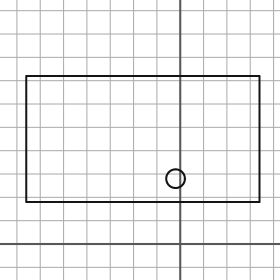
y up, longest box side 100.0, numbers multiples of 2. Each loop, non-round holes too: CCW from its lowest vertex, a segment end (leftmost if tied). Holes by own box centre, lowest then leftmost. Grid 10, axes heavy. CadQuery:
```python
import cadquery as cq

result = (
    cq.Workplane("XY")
    .moveTo(-66.0, 18.0)
    .lineTo(34.0, 18.0)
    .lineTo(34.0, 72.0)
    .lineTo(-66.0, 72.0)
    .close()
    .moveTo(-2.0, 28.0)
    .circle(4.0)
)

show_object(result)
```